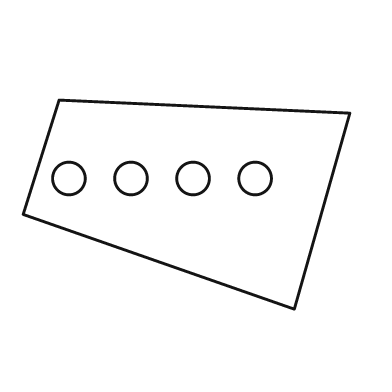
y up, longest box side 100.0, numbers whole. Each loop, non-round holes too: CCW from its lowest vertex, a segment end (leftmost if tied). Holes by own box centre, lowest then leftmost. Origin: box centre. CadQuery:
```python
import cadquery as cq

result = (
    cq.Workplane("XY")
    .moveTo(33.0, -32.0)
    .lineTo(50.0, 28.0)
    .lineTo(-39.0, 32.0)
    .lineTo(-50.0, -3.0)
    .close()
    .moveTo(-36.0, 8.0)
    .circle(5.0)
    .moveTo(-17.0, 8.0)
    .circle(5.0)
    .moveTo(2.0, 8.0)
    .circle(5.0)
    .moveTo(21.0, 8.0)
    .circle(5.0)
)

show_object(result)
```